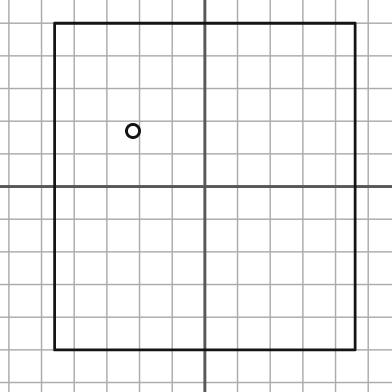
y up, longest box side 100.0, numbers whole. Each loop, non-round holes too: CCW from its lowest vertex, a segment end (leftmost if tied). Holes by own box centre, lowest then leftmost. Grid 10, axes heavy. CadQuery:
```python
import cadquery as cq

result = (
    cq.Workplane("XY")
    .moveTo(-46.0, -50.0)
    .lineTo(46.0, -50.0)
    .lineTo(46.0, 50.0)
    .lineTo(-46.0, 50.0)
    .close()
    .moveTo(-22.0, 17.0)
    .circle(2.0)
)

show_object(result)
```